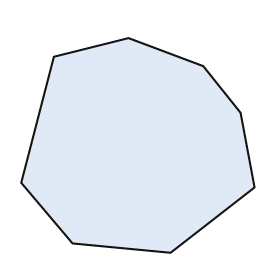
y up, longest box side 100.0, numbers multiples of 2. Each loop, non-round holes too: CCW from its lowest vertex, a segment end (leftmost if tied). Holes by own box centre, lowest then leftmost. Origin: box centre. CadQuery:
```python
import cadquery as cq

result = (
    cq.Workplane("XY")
    .moveTo(14.0, -46.0)
    .lineTo(50.0, -18.0)
    .lineTo(44.0, 14.0)
    .lineTo(28.0, 34.0)
    .lineTo(-4.0, 46.0)
    .lineTo(-36.0, 38.0)
    .lineTo(-50.0, -16.0)
    .lineTo(-28.0, -42.0)
    .close()
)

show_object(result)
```